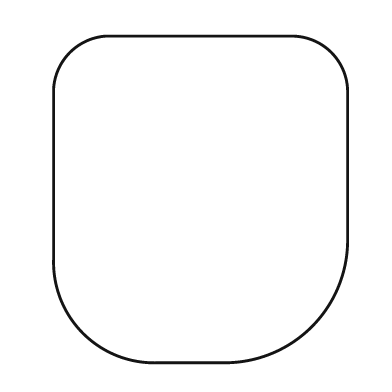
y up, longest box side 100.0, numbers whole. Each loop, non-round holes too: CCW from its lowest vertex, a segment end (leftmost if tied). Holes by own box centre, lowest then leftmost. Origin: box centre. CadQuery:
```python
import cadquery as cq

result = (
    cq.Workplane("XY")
    .moveTo(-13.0, -50.0)
    .lineTo(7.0, -50.0)
    .threePointArc((34.0, -39.0), (45.0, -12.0))
    .lineTo(45.0, 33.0)
    .threePointArc((40.0, 45.0), (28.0, 50.0))
    .lineTo(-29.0, 50.0)
    .threePointArc((-40.0, 45.0), (-45.0, 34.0))
    .lineTo(-45.0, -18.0)
    .threePointArc((-36.0, -41.0), (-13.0, -50.0))
    .close()
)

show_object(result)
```